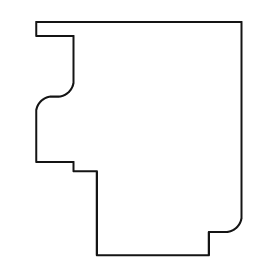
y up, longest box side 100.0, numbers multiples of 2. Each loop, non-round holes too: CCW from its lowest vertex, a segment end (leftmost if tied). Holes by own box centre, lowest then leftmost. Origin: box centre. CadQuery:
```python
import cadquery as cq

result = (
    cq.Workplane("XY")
    .moveTo(-18.0, -50.0)
    .lineTo(30.0, -50.0)
    .lineTo(30.0, -40.0)
    .lineTo(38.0, -40.0)
    .threePointArc((42.0, -38.0), (44.0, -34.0))
    .lineTo(44.0, 50.0)
    .lineTo(-44.0, 50.0)
    .lineTo(-44.0, 44.0)
    .lineTo(-28.0, 44.0)
    .lineTo(-28.0, 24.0)
    .threePointArc((-30.0, 20.0), (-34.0, 18.0))
    .lineTo(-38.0, 18.0)
    .threePointArc((-42.0, 16.0), (-44.0, 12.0))
    .lineTo(-44.0, -10.0)
    .lineTo(-28.0, -10.0)
    .lineTo(-28.0, -14.0)
    .lineTo(-18.0, -14.0)
    .close()
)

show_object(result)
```